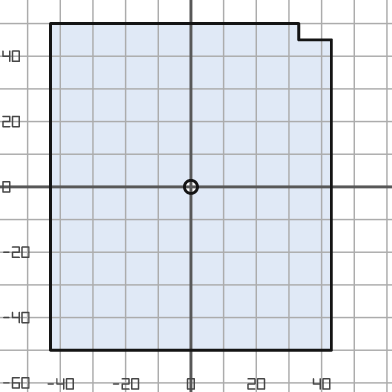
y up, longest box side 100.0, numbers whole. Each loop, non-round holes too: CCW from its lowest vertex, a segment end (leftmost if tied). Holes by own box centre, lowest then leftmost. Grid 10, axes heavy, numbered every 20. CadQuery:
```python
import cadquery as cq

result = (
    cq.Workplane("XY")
    .moveTo(-43.0, -50.0)
    .lineTo(43.0, -50.0)
    .lineTo(43.0, 45.0)
    .lineTo(33.0, 45.0)
    .lineTo(33.0, 50.0)
    .lineTo(-43.0, 50.0)
    .close()
    .moveTo(0.0, 0.0)
    .circle(2.0)
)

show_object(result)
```